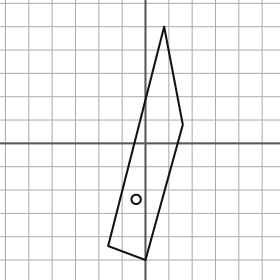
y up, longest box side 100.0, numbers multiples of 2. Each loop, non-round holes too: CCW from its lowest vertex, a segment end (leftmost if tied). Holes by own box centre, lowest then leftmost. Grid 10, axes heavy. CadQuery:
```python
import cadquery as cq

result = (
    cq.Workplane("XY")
    .moveTo(0.0, -50.0)
    .lineTo(16.0, 8.0)
    .lineTo(8.0, 50.0)
    .lineTo(-16.0, -44.0)
    .close()
    .moveTo(-4.0, -24.0)
    .circle(2.0)
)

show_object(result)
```